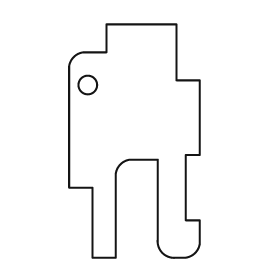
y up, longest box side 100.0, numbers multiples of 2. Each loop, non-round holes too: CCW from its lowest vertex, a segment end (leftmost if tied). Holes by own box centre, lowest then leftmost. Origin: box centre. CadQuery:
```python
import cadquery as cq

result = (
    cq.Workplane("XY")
    .moveTo(-18.0, -50.0)
    .lineTo(-8.0, -50.0)
    .lineTo(-8.0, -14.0)
    .threePointArc((-6.0, -10.0), (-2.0, -8.0))
    .lineTo(10.0, -8.0)
    .lineTo(10.0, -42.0)
    .threePointArc((12.0, -48.0), (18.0, -50.0))
    .lineTo(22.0, -50.0)
    .threePointArc((26.0, -48.0), (28.0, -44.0))
    .lineTo(28.0, -34.0)
    .lineTo(22.0, -34.0)
    .lineTo(22.0, -6.0)
    .lineTo(28.0, -6.0)
    .lineTo(28.0, 26.0)
    .lineTo(18.0, 26.0)
    .lineTo(18.0, 50.0)
    .lineTo(-12.0, 50.0)
    .lineTo(-12.0, 38.0)
    .lineTo(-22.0, 38.0)
    .threePointArc((-26.0, 36.0), (-28.0, 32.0))
    .lineTo(-28.0, -20.0)
    .lineTo(-18.0, -20.0)
    .close()
    .moveTo(-20.0, 24.0)
    .circle(4.0)
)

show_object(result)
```